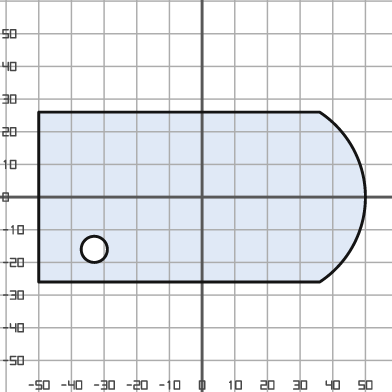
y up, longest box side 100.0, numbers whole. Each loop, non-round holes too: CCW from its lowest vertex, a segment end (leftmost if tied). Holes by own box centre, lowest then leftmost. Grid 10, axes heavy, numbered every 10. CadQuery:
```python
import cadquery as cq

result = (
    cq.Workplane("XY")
    .moveTo(-50.0, -26.0)
    .lineTo(36.0, -26.0)
    .threePointArc((50.0, 0.0), (36.0, 26.0))
    .lineTo(-50.0, 26.0)
    .close()
    .moveTo(-33.0, -16.0)
    .circle(4.0)
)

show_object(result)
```